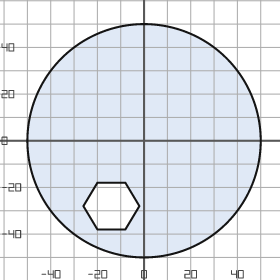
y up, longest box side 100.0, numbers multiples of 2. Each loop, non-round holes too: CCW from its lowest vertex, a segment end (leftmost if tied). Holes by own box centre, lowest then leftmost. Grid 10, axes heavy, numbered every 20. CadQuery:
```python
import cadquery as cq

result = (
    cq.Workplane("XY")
    .moveTo(0.0, 0.0)
    .circle(50.0)
    .moveTo(-20.0, -38.0)
    .lineTo(-8.0, -38.0)
    .lineTo(-2.0, -28.0)
    .lineTo(-8.0, -18.0)
    .lineTo(-20.0, -18.0)
    .lineTo(-26.0, -28.0)
    .close()
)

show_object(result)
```